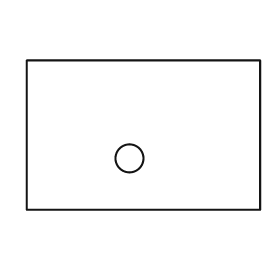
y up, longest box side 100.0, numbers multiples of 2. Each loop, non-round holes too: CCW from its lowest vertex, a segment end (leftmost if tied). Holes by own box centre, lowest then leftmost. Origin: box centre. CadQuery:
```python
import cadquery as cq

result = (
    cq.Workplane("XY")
    .moveTo(-50.0, -32.0)
    .lineTo(50.0, -32.0)
    .lineTo(50.0, 32.0)
    .lineTo(-50.0, 32.0)
    .close()
    .moveTo(-6.0, -10.0)
    .circle(6.0)
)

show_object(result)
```